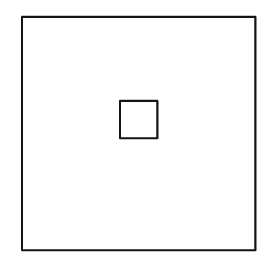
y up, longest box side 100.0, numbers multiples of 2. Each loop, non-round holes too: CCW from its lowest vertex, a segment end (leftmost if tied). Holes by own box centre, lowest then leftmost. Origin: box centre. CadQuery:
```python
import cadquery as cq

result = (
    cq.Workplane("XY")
    .moveTo(-50.0, -50.0)
    .lineTo(50.0, -50.0)
    .lineTo(50.0, 50.0)
    .lineTo(-50.0, 50.0)
    .close()
    .moveTo(-8.0, -2.0)
    .lineTo(8.0, -2.0)
    .lineTo(8.0, 14.0)
    .lineTo(-8.0, 14.0)
    .close()
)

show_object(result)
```